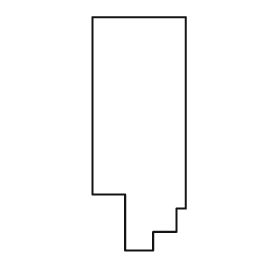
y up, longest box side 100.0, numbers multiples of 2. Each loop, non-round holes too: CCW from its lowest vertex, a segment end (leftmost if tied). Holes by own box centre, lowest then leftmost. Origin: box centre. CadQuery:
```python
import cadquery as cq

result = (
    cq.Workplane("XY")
    .moveTo(-6.0, -50.0)
    .lineTo(6.0, -50.0)
    .lineTo(6.0, -42.0)
    .lineTo(16.0, -42.0)
    .lineTo(16.0, -32.0)
    .lineTo(20.0, -32.0)
    .lineTo(20.0, 50.0)
    .lineTo(-20.0, 50.0)
    .lineTo(-20.0, -26.0)
    .lineTo(-6.0, -26.0)
    .close()
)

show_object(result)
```